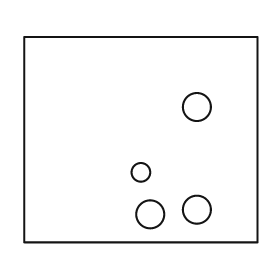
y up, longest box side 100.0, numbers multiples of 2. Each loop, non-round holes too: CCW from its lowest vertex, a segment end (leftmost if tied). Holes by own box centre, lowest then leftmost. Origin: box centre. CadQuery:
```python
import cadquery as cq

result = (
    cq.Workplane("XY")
    .moveTo(-50.0, -44.0)
    .lineTo(50.0, -44.0)
    .lineTo(50.0, 44.0)
    .lineTo(-50.0, 44.0)
    .close()
    .moveTo(4.0, -32.0)
    .circle(6.0)
    .moveTo(24.0, -30.0)
    .circle(6.0)
    .moveTo(0.0, -14.0)
    .circle(4.0)
    .moveTo(24.0, 14.0)
    .circle(6.0)
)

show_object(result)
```